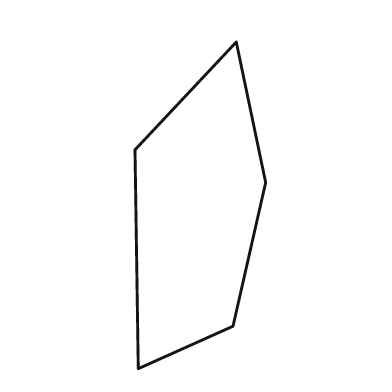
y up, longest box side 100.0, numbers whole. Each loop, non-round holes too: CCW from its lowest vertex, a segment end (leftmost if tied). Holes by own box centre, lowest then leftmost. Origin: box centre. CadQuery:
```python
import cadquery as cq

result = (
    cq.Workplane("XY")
    .moveTo(-19.0, -50.0)
    .lineTo(10.0, -37.0)
    .lineTo(20.0, 7.0)
    .lineTo(11.0, 50.0)
    .lineTo(-20.0, 17.0)
    .close()
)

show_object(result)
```